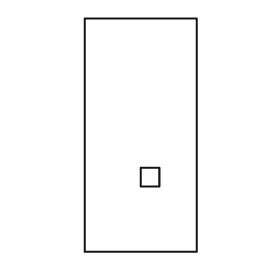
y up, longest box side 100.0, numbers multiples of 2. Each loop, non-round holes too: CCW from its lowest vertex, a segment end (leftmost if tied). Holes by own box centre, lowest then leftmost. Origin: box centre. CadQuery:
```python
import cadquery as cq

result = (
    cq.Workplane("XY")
    .moveTo(-24.0, -50.0)
    .lineTo(24.0, -50.0)
    .lineTo(24.0, 50.0)
    .lineTo(-24.0, 50.0)
    .close()
    .moveTo(0.0, -22.0)
    .lineTo(8.0, -22.0)
    .lineTo(8.0, -14.0)
    .lineTo(0.0, -14.0)
    .close()
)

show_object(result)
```